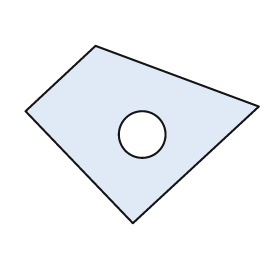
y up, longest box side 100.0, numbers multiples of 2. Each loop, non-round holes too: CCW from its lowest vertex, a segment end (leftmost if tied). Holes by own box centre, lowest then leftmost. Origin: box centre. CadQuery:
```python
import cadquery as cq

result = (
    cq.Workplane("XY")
    .moveTo(-4.0, -38.0)
    .lineTo(50.0, 12.0)
    .lineTo(-20.0, 38.0)
    .lineTo(-50.0, 10.0)
    .close()
    .moveTo(0.0, 0.0)
    .circle(10.0)
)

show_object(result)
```